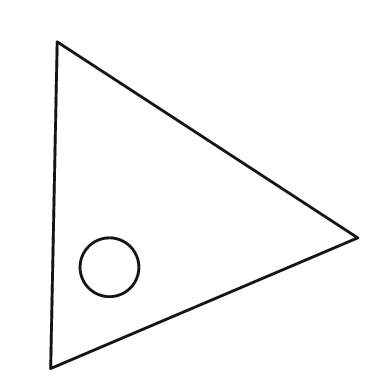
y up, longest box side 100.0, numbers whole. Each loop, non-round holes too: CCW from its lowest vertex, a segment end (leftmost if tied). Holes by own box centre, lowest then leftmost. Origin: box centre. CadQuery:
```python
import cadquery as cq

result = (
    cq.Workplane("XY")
    .moveTo(-47.0, -50.0)
    .lineTo(47.0, -10.0)
    .lineTo(-45.0, 50.0)
    .close()
    .moveTo(-29.0, -19.0)
    .circle(9.0)
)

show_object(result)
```